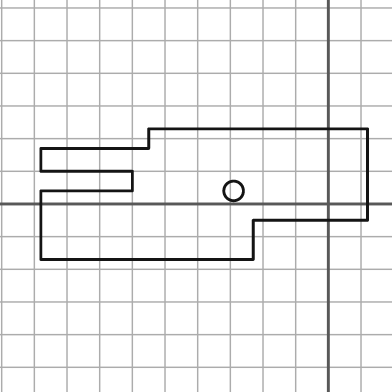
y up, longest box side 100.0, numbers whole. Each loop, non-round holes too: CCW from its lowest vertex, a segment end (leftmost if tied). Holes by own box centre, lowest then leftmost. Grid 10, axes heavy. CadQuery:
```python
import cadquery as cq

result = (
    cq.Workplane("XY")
    .moveTo(-88.0, -17.0)
    .lineTo(-23.0, -17.0)
    .lineTo(-23.0, -5.0)
    .lineTo(12.0, -5.0)
    .lineTo(12.0, 23.0)
    .lineTo(-55.0, 23.0)
    .lineTo(-55.0, 17.0)
    .lineTo(-88.0, 17.0)
    .lineTo(-88.0, 10.0)
    .lineTo(-60.0, 10.0)
    .lineTo(-60.0, 4.0)
    .lineTo(-88.0, 4.0)
    .close()
    .moveTo(-29.0, 4.0)
    .circle(3.0)
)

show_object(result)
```